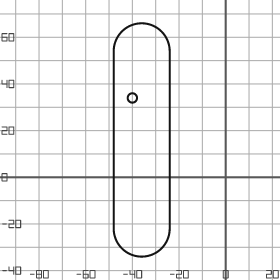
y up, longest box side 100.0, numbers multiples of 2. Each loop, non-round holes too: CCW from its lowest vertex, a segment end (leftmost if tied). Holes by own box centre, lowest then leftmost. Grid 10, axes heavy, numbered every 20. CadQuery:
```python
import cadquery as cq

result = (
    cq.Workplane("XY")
    .moveTo(-48.0, -22.0)
    .threePointArc((-36.0, -34.0), (-24.0, -22.0))
    .lineTo(-24.0, 54.0)
    .threePointArc((-36.0, 66.0), (-48.0, 54.0))
    .close()
    .moveTo(-40.0, 34.0)
    .circle(2.0)
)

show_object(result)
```